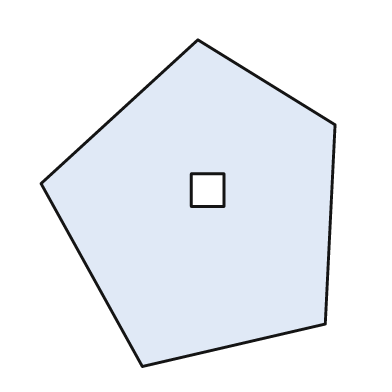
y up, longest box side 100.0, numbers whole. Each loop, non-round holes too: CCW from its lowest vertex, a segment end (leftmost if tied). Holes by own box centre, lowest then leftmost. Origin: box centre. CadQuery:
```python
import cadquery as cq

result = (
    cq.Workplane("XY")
    .moveTo(-14.0, -50.0)
    .lineTo(42.0, -37.0)
    .lineTo(45.0, 24.0)
    .lineTo(3.0, 50.0)
    .lineTo(-45.0, 6.0)
    .close()
    .moveTo(1.0, -1.0)
    .lineTo(11.0, -1.0)
    .lineTo(11.0, 9.0)
    .lineTo(1.0, 9.0)
    .close()
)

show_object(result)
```